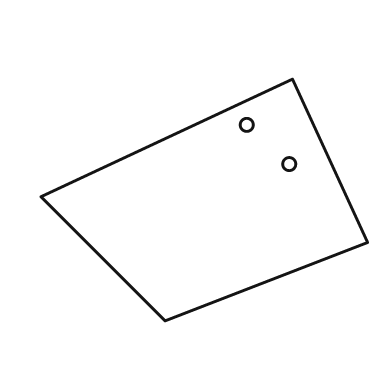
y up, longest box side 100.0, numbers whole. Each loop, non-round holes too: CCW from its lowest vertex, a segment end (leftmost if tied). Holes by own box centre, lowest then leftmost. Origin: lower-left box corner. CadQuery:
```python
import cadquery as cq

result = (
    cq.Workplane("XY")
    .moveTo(38.0, 0.0)
    .lineTo(100.0, 24.0)
    .lineTo(77.0, 74.0)
    .lineTo(0.0, 38.0)
    .close()
    .moveTo(76.0, 48.0)
    .circle(2.0)
    .moveTo(63.0, 60.0)
    .circle(2.0)
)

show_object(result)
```